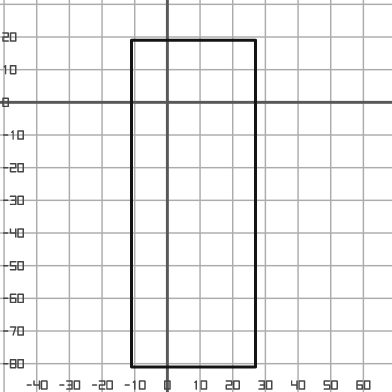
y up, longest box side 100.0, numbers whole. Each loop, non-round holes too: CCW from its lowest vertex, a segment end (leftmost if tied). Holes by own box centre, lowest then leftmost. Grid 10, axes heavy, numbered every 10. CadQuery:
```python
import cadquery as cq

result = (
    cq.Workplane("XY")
    .moveTo(-11.0, -81.0)
    .lineTo(27.0, -81.0)
    .lineTo(27.0, 19.0)
    .lineTo(-11.0, 19.0)
    .close()
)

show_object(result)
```